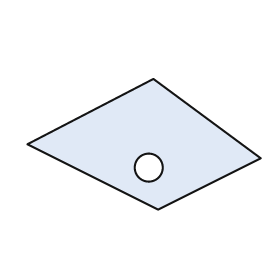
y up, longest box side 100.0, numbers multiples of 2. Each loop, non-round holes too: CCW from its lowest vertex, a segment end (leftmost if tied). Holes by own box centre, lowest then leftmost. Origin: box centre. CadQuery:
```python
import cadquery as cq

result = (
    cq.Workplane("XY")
    .moveTo(6.0, -28.0)
    .lineTo(50.0, -6.0)
    .lineTo(4.0, 28.0)
    .lineTo(-50.0, 0.0)
    .close()
    .moveTo(2.0, -10.0)
    .circle(6.0)
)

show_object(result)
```